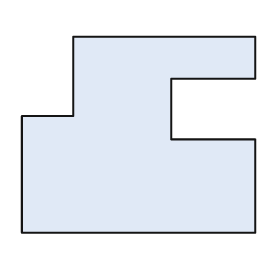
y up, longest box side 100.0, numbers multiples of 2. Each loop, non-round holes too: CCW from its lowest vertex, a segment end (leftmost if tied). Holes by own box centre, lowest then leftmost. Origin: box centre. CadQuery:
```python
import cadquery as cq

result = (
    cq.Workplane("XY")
    .moveTo(-50.0, -42.0)
    .lineTo(50.0, -42.0)
    .lineTo(50.0, -2.0)
    .lineTo(14.0, -2.0)
    .lineTo(14.0, 24.0)
    .lineTo(50.0, 24.0)
    .lineTo(50.0, 42.0)
    .lineTo(-28.0, 42.0)
    .lineTo(-28.0, 8.0)
    .lineTo(-50.0, 8.0)
    .close()
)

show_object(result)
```